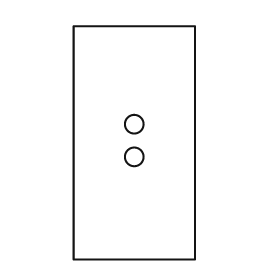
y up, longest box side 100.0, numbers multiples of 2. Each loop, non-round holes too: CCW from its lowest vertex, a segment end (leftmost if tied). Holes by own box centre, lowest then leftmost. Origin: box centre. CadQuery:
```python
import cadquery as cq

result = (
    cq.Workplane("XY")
    .moveTo(-26.0, -50.0)
    .lineTo(26.0, -50.0)
    .lineTo(26.0, 50.0)
    .lineTo(-26.0, 50.0)
    .close()
    .moveTo(0.0, -6.0)
    .circle(4.0)
    .moveTo(0.0, 8.0)
    .circle(4.0)
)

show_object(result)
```